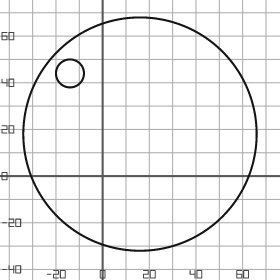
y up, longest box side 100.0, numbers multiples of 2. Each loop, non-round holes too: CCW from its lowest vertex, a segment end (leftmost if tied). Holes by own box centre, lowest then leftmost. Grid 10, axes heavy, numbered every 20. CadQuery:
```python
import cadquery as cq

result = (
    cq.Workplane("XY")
    .moveTo(16.0, 18.0)
    .circle(50.0)
    .moveTo(-14.0, 44.0)
    .circle(6.0)
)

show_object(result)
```